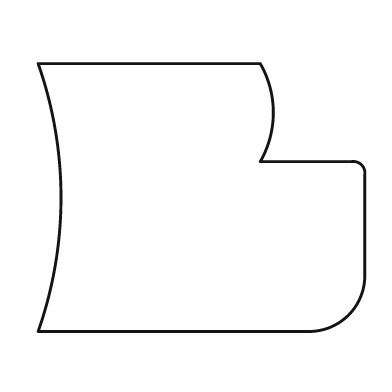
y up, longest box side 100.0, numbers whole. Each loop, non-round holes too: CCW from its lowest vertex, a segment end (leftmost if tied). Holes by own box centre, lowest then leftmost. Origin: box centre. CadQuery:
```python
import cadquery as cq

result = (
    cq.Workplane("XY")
    .moveTo(-50.0, -41.0)
    .lineTo(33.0, -41.0)
    .threePointArc((45.0, -36.0), (50.0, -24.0))
    .lineTo(50.0, 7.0)
    .threePointArc((49.0, 10.0), (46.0, 11.0))
    .lineTo(18.0, 11.0)
    .threePointArc((22.0, 26.0), (18.0, 41.0))
    .lineTo(-50.0, 41.0)
    .threePointArc((-43.0, 0.0), (-50.0, -41.0))
    .close()
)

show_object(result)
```